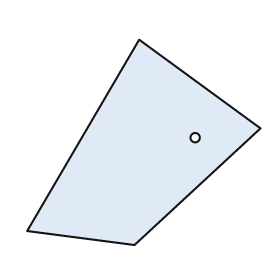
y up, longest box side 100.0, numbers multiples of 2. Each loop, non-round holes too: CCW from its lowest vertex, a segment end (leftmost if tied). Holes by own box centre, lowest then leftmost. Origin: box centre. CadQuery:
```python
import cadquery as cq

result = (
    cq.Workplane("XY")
    .moveTo(-4.0, -44.0)
    .lineTo(50.0, 6.0)
    .lineTo(-2.0, 44.0)
    .lineTo(-50.0, -38.0)
    .close()
    .moveTo(22.0, 2.0)
    .circle(2.0)
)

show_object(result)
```